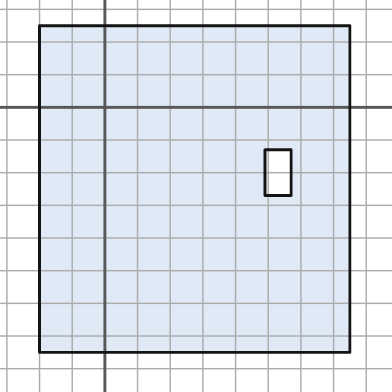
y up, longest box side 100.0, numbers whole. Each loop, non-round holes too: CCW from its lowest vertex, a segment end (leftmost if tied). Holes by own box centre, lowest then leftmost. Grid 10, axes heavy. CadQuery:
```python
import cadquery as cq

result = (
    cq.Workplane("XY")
    .moveTo(-20.0, -75.0)
    .lineTo(75.0, -75.0)
    .lineTo(75.0, 25.0)
    .lineTo(-20.0, 25.0)
    .close()
    .moveTo(49.0, -27.0)
    .lineTo(57.0, -27.0)
    .lineTo(57.0, -13.0)
    .lineTo(49.0, -13.0)
    .close()
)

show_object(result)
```